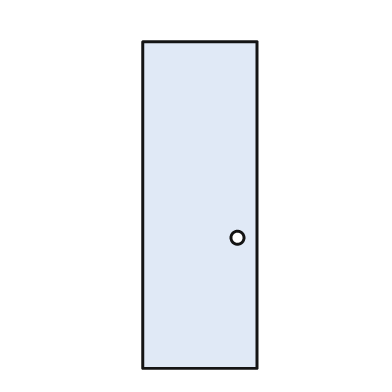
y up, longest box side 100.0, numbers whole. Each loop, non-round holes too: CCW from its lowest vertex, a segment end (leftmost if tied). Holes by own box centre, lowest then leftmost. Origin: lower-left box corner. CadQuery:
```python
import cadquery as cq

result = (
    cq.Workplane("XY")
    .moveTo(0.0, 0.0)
    .lineTo(35.0, 0.0)
    .lineTo(35.0, 100.0)
    .lineTo(0.0, 100.0)
    .close()
    .moveTo(29.0, 40.0)
    .circle(2.0)
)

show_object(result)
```